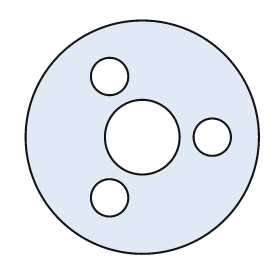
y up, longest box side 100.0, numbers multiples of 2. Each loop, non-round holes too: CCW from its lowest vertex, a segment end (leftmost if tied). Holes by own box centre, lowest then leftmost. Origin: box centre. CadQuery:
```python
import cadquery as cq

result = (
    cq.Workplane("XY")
    .moveTo(0.0, 0.0)
    .circle(50.0)
    .moveTo(-14.0, -26.0)
    .circle(8.0)
    .moveTo(0.0, 0.0)
    .circle(16.0)
    .moveTo(30.0, 0.0)
    .circle(8.0)
    .moveTo(-14.0, 26.0)
    .circle(8.0)
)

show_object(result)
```